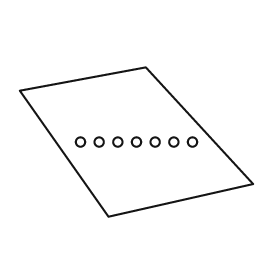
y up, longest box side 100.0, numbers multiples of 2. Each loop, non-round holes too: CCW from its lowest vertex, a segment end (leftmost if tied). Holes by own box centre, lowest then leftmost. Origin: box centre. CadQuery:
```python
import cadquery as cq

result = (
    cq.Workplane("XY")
    .moveTo(-12.0, -32.0)
    .lineTo(50.0, -18.0)
    .lineTo(4.0, 32.0)
    .lineTo(-50.0, 22.0)
    .close()
    .moveTo(-24.0, 0.0)
    .circle(2.0)
    .moveTo(-16.0, 0.0)
    .circle(2.0)
    .moveTo(-8.0, 0.0)
    .circle(2.0)
    .moveTo(0.0, 0.0)
    .circle(2.0)
    .moveTo(8.0, 0.0)
    .circle(2.0)
    .moveTo(16.0, 0.0)
    .circle(2.0)
    .moveTo(24.0, 0.0)
    .circle(2.0)
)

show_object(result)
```